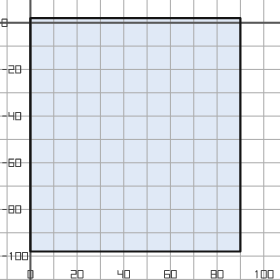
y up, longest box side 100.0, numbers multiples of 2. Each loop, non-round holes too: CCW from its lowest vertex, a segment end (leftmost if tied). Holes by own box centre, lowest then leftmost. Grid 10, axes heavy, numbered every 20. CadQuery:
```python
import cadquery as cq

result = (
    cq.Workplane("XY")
    .moveTo(0.0, -98.0)
    .lineTo(90.0, -98.0)
    .lineTo(90.0, 2.0)
    .lineTo(0.0, 2.0)
    .close()
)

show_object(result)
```